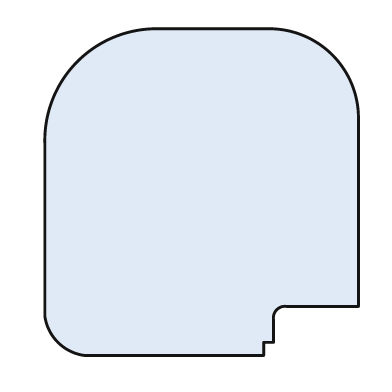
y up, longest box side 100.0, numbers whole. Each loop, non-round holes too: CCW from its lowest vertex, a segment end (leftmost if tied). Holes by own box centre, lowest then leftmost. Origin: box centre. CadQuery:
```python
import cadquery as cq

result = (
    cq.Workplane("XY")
    .moveTo(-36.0, -50.0)
    .lineTo(19.0, -50.0)
    .lineTo(19.0, -46.0)
    .lineTo(22.0, -46.0)
    .lineTo(22.0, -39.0)
    .threePointArc((23.0, -36.0), (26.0, -35.0))
    .lineTo(48.0, -35.0)
    .lineTo(48.0, 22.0)
    .threePointArc((40.0, 42.0), (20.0, 50.0))
    .lineTo(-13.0, 50.0)
    .threePointArc((-38.0, 40.0), (-48.0, 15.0))
    .lineTo(-48.0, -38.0)
    .threePointArc((-44.0, -46.0), (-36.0, -50.0))
    .close()
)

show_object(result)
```